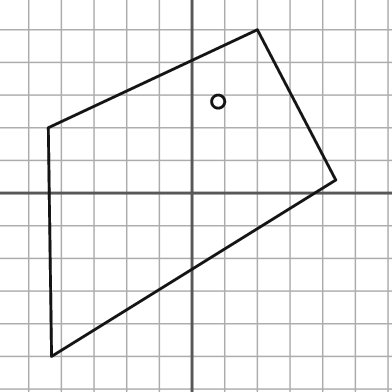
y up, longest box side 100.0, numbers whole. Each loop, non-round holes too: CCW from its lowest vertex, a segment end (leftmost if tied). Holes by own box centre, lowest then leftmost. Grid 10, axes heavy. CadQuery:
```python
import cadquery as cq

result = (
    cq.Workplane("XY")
    .moveTo(-43.0, -50.0)
    .lineTo(44.0, 4.0)
    .lineTo(20.0, 50.0)
    .lineTo(-44.0, 20.0)
    .close()
    .moveTo(8.0, 28.0)
    .circle(2.0)
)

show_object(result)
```